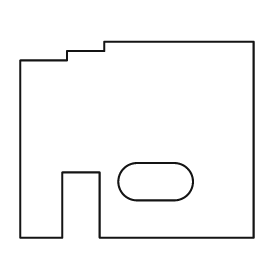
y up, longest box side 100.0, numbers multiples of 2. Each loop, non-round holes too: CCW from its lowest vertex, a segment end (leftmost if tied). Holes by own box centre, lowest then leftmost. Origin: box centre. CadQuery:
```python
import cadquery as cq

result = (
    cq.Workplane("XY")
    .moveTo(-50.0, -42.0)
    .lineTo(-32.0, -42.0)
    .lineTo(-32.0, -14.0)
    .lineTo(-16.0, -14.0)
    .lineTo(-16.0, -42.0)
    .lineTo(50.0, -42.0)
    .lineTo(50.0, 42.0)
    .lineTo(-14.0, 42.0)
    .lineTo(-14.0, 38.0)
    .lineTo(-30.0, 38.0)
    .lineTo(-30.0, 34.0)
    .lineTo(-50.0, 34.0)
    .close()
    .moveTo(0.0, -26.0)
    .lineTo(16.0, -26.0)
    .threePointArc((24.0, -18.0), (16.0, -10.0))
    .lineTo(0.0, -10.0)
    .threePointArc((-8.0, -18.0), (0.0, -26.0))
    .close()
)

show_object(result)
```